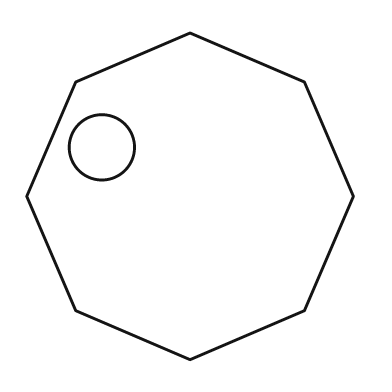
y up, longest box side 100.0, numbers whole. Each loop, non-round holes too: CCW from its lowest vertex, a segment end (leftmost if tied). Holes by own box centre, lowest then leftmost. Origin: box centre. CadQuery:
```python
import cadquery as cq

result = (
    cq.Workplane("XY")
    .moveTo(0.0, -50.0)
    .lineTo(35.0, -35.0)
    .lineTo(50.0, 0.0)
    .lineTo(35.0, 35.0)
    .lineTo(0.0, 50.0)
    .lineTo(-35.0, 35.0)
    .lineTo(-50.0, 0.0)
    .lineTo(-35.0, -35.0)
    .close()
    .moveTo(-27.0, 15.0)
    .circle(10.0)
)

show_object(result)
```